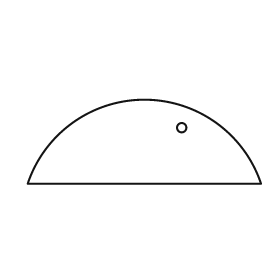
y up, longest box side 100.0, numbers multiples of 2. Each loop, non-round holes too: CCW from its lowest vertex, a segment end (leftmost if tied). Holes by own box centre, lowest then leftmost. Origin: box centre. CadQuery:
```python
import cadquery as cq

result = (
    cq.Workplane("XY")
    .moveTo(-50.0, -18.0)
    .lineTo(50.0, -18.0)
    .threePointArc((0.0, 18.0), (-50.0, -18.0))
    .close()
    .moveTo(16.0, 6.0)
    .circle(2.0)
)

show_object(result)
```